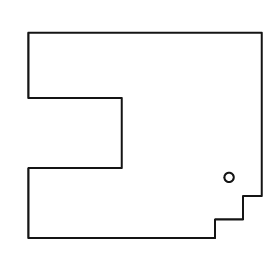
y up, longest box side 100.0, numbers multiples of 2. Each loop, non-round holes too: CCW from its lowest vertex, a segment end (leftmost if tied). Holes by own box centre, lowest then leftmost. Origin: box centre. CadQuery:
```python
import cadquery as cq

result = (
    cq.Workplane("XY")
    .moveTo(-50.0, -44.0)
    .lineTo(30.0, -44.0)
    .lineTo(30.0, -36.0)
    .lineTo(42.0, -36.0)
    .lineTo(42.0, -26.0)
    .lineTo(50.0, -26.0)
    .lineTo(50.0, 44.0)
    .lineTo(-50.0, 44.0)
    .lineTo(-50.0, 16.0)
    .lineTo(-10.0, 16.0)
    .lineTo(-10.0, -14.0)
    .lineTo(-50.0, -14.0)
    .close()
    .moveTo(36.0, -18.0)
    .circle(2.0)
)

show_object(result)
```